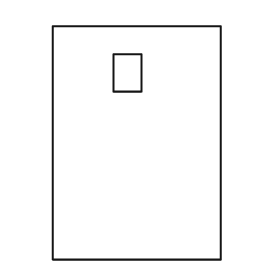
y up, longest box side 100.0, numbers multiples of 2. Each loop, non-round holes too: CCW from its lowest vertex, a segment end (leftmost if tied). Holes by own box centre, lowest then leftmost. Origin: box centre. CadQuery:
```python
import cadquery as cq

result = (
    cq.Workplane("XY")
    .moveTo(-36.0, -50.0)
    .lineTo(36.0, -50.0)
    .lineTo(36.0, 50.0)
    .lineTo(-36.0, 50.0)
    .close()
    .moveTo(-10.0, 22.0)
    .lineTo(2.0, 22.0)
    .lineTo(2.0, 38.0)
    .lineTo(-10.0, 38.0)
    .close()
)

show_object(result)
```